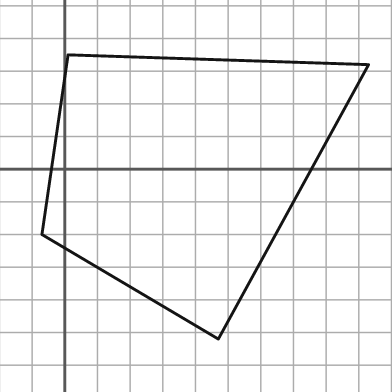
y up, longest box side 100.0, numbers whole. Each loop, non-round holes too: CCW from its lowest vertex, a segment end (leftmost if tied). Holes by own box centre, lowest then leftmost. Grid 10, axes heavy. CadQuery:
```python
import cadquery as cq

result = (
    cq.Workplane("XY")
    .moveTo(47.0, -52.0)
    .lineTo(93.0, 32.0)
    .lineTo(1.0, 35.0)
    .lineTo(-7.0, -20.0)
    .close()
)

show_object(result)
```